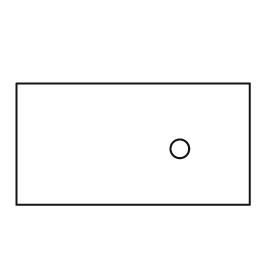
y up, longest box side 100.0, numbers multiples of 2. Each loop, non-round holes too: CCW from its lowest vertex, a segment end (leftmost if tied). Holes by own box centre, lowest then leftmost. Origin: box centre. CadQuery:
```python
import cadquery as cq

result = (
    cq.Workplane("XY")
    .moveTo(-50.0, -26.0)
    .lineTo(50.0, -26.0)
    .lineTo(50.0, 26.0)
    .lineTo(-50.0, 26.0)
    .close()
    .moveTo(20.0, -2.0)
    .circle(4.0)
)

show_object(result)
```